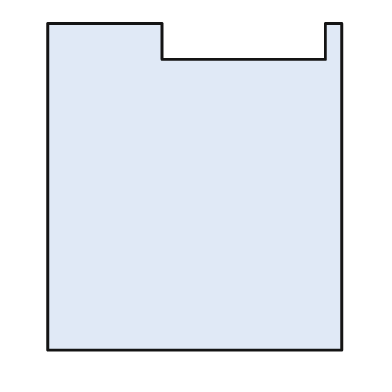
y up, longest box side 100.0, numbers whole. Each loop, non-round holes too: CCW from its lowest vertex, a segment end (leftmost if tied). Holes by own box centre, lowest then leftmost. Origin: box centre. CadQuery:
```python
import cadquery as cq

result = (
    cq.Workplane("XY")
    .moveTo(-45.0, -50.0)
    .lineTo(45.0, -50.0)
    .lineTo(45.0, 50.0)
    .lineTo(40.0, 50.0)
    .lineTo(40.0, 39.0)
    .lineTo(-10.0, 39.0)
    .lineTo(-10.0, 50.0)
    .lineTo(-45.0, 50.0)
    .close()
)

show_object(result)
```